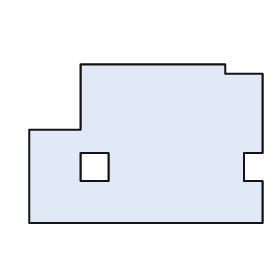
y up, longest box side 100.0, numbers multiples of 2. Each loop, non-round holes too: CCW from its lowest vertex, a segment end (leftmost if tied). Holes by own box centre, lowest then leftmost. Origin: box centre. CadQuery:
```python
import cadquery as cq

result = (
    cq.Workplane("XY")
    .moveTo(-50.0, -34.0)
    .lineTo(50.0, -34.0)
    .lineTo(50.0, -16.0)
    .lineTo(42.0, -16.0)
    .lineTo(42.0, -4.0)
    .lineTo(50.0, -4.0)
    .lineTo(50.0, 30.0)
    .lineTo(34.0, 30.0)
    .lineTo(34.0, 34.0)
    .lineTo(-28.0, 34.0)
    .lineTo(-28.0, 6.0)
    .lineTo(-50.0, 6.0)
    .close()
    .moveTo(-28.0, -16.0)
    .lineTo(-16.0, -16.0)
    .lineTo(-16.0, -4.0)
    .lineTo(-28.0, -4.0)
    .close()
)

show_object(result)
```